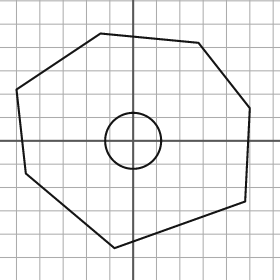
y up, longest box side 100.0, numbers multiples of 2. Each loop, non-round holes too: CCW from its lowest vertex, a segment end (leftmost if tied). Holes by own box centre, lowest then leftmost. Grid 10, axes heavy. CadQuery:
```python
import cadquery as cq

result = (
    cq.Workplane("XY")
    .moveTo(-8.0, -46.0)
    .lineTo(48.0, -26.0)
    .lineTo(50.0, 14.0)
    .lineTo(28.0, 42.0)
    .lineTo(-14.0, 46.0)
    .lineTo(-50.0, 22.0)
    .lineTo(-46.0, -14.0)
    .close()
    .moveTo(0.0, 0.0)
    .circle(12.0)
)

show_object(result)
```